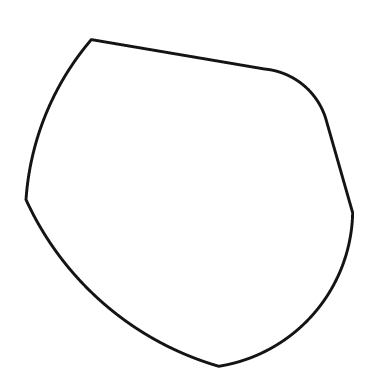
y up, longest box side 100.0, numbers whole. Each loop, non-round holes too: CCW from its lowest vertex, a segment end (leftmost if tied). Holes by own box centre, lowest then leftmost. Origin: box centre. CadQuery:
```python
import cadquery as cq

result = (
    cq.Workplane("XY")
    .moveTo(9.0, -50.0)
    .threePointArc((38.0, -34.0), (50.0, -3.0))
    .lineTo(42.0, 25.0)
    .threePointArc((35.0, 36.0), (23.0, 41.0))
    .lineTo(-30.0, 50.0)
    .threePointArc((-44.0, 27.0), (-50.0, 1.0))
    .threePointArc((-26.0, -31.0), (9.0, -50.0))
    .close()
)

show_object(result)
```